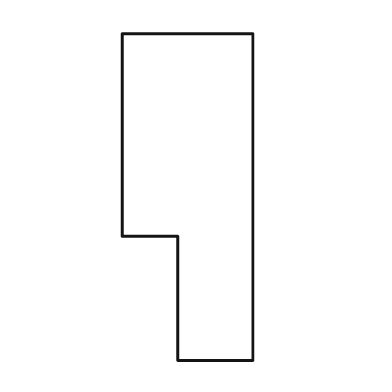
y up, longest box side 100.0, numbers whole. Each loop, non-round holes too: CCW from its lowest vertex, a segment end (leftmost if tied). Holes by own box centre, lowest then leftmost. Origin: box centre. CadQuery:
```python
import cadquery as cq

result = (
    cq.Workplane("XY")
    .moveTo(-3.0, -50.0)
    .lineTo(20.0, -50.0)
    .lineTo(20.0, 50.0)
    .lineTo(-20.0, 50.0)
    .lineTo(-20.0, -12.0)
    .lineTo(-3.0, -12.0)
    .close()
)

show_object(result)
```